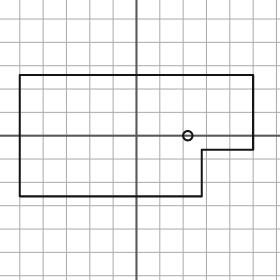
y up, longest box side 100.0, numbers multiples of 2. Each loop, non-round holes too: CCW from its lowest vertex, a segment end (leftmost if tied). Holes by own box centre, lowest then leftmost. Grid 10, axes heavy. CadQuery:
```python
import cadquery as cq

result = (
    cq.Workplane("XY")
    .moveTo(-50.0, -26.0)
    .lineTo(28.0, -26.0)
    .lineTo(28.0, -6.0)
    .lineTo(50.0, -6.0)
    .lineTo(50.0, 26.0)
    .lineTo(-50.0, 26.0)
    .close()
    .moveTo(22.0, 0.0)
    .circle(2.0)
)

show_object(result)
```